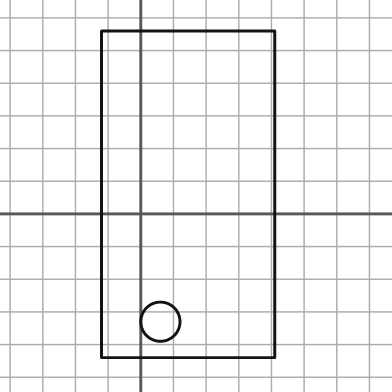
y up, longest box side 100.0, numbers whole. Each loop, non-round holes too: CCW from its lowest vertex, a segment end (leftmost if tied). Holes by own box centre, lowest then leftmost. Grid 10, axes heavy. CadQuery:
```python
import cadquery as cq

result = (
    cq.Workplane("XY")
    .moveTo(-12.0, -44.0)
    .lineTo(41.0, -44.0)
    .lineTo(41.0, 56.0)
    .lineTo(-12.0, 56.0)
    .close()
    .moveTo(6.0, -33.0)
    .circle(6.0)
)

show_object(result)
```